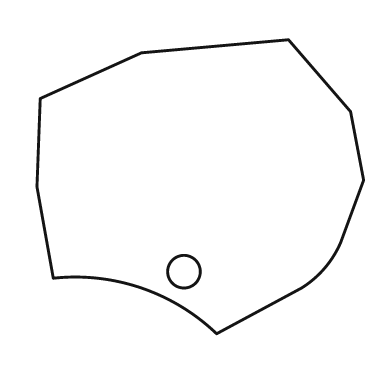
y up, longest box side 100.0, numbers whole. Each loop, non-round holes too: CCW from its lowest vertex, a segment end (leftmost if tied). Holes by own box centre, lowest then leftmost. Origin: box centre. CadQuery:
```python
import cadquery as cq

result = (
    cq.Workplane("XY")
    .moveTo(5.0, -45.0)
    .lineTo(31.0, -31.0)
    .threePointArc((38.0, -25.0), (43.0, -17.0))
    .lineTo(50.0, 2.0)
    .lineTo(46.0, 23.0)
    .lineTo(27.0, 45.0)
    .lineTo(-18.0, 41.0)
    .lineTo(-49.0, 27.0)
    .lineTo(-50.0, 0.0)
    .lineTo(-45.0, -28.0)
    .threePointArc((-18.0, -31.0), (5.0, -45.0))
    .close()
    .moveTo(-5.0, -26.0)
    .circle(5.0)
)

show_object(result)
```